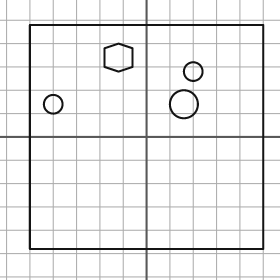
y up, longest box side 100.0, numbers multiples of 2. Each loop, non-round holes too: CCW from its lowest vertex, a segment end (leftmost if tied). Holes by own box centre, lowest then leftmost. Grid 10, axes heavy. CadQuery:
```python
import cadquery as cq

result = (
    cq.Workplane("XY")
    .moveTo(-50.0, -48.0)
    .lineTo(50.0, -48.0)
    .lineTo(50.0, 48.0)
    .lineTo(-50.0, 48.0)
    .close()
    .moveTo(-40.0, 14.0)
    .circle(4.0)
    .moveTo(16.0, 14.0)
    .circle(6.0)
    .moveTo(20.0, 28.0)
    .circle(4.0)
    .moveTo(-12.0, 28.0)
    .lineTo(-6.0, 30.0)
    .lineTo(-6.0, 38.0)
    .lineTo(-12.0, 40.0)
    .lineTo(-18.0, 38.0)
    .lineTo(-18.0, 30.0)
    .close()
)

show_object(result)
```